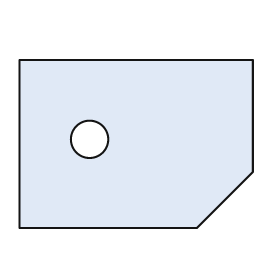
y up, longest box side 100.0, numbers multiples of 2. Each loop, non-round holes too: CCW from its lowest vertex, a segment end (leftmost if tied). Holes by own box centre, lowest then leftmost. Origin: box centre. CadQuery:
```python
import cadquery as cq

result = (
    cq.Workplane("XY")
    .moveTo(-50.0, -36.0)
    .lineTo(26.0, -36.0)
    .lineTo(50.0, -12.0)
    .lineTo(50.0, 36.0)
    .lineTo(-50.0, 36.0)
    .close()
    .moveTo(-20.0, 2.0)
    .circle(8.0)
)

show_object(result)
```